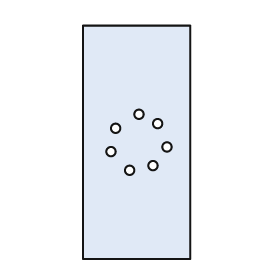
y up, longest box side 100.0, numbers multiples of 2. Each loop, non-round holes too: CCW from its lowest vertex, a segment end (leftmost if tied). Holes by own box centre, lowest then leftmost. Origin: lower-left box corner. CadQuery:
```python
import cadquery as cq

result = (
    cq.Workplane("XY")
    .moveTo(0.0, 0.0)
    .lineTo(46.0, 0.0)
    .lineTo(46.0, 100.0)
    .lineTo(0.0, 100.0)
    .close()
    .moveTo(20.0, 38.0)
    .circle(2.0)
    .moveTo(30.0, 40.0)
    .circle(2.0)
    .moveTo(12.0, 46.0)
    .circle(2.0)
    .moveTo(36.0, 48.0)
    .circle(2.0)
    .moveTo(14.0, 56.0)
    .circle(2.0)
    .moveTo(32.0, 58.0)
    .circle(2.0)
    .moveTo(24.0, 62.0)
    .circle(2.0)
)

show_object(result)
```